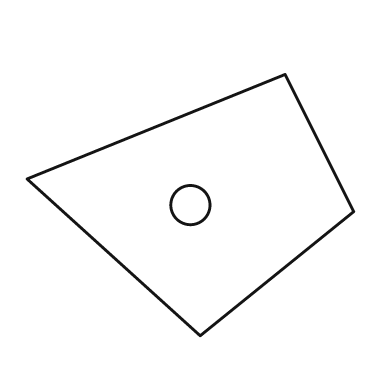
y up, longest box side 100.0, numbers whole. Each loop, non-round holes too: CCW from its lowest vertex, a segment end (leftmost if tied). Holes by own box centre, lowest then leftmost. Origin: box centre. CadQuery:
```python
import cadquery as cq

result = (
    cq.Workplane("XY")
    .moveTo(3.0, -40.0)
    .lineTo(50.0, -2.0)
    .lineTo(29.0, 40.0)
    .lineTo(-50.0, 8.0)
    .close()
    .moveTo(0.0, 0.0)
    .circle(6.0)
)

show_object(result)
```